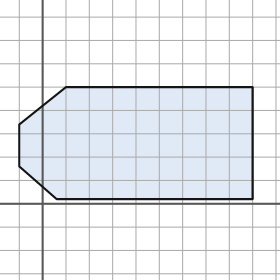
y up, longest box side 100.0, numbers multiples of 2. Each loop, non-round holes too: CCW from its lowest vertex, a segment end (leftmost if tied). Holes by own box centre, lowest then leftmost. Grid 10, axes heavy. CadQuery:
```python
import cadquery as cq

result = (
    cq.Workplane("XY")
    .moveTo(6.0, 2.0)
    .lineTo(90.0, 2.0)
    .lineTo(90.0, 50.0)
    .lineTo(10.0, 50.0)
    .lineTo(-10.0, 34.0)
    .lineTo(-10.0, 16.0)
    .close()
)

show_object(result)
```